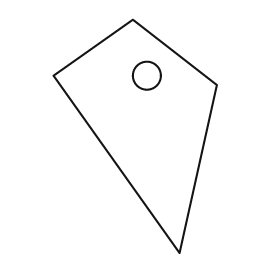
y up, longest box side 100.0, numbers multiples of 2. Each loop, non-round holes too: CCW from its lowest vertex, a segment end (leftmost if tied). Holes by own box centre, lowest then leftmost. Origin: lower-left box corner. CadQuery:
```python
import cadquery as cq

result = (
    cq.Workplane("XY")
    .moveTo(54.0, 0.0)
    .lineTo(70.0, 72.0)
    .lineTo(34.0, 100.0)
    .lineTo(0.0, 76.0)
    .close()
    .moveTo(40.0, 76.0)
    .circle(6.0)
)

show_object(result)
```